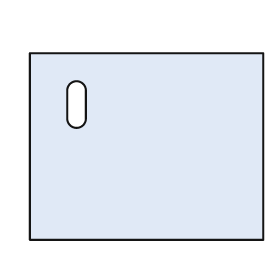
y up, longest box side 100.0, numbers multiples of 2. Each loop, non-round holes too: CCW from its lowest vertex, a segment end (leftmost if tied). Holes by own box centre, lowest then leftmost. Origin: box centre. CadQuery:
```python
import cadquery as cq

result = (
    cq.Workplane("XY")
    .moveTo(-50.0, -40.0)
    .lineTo(50.0, -40.0)
    .lineTo(50.0, 40.0)
    .lineTo(-50.0, 40.0)
    .close()
    .moveTo(-34.0, 12.0)
    .threePointArc((-30.0, 8.0), (-26.0, 12.0))
    .lineTo(-26.0, 24.0)
    .threePointArc((-30.0, 28.0), (-34.0, 24.0))
    .close()
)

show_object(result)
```